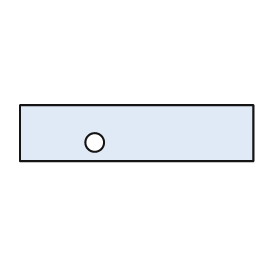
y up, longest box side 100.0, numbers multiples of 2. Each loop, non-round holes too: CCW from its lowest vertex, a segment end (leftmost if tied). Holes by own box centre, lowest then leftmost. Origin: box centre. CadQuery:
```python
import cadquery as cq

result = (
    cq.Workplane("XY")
    .moveTo(-50.0, -12.0)
    .lineTo(50.0, -12.0)
    .lineTo(50.0, 12.0)
    .lineTo(-50.0, 12.0)
    .close()
    .moveTo(-18.0, -4.0)
    .circle(4.0)
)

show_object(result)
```